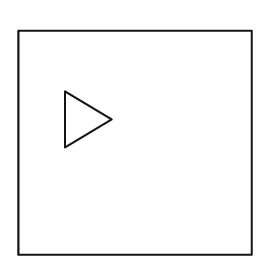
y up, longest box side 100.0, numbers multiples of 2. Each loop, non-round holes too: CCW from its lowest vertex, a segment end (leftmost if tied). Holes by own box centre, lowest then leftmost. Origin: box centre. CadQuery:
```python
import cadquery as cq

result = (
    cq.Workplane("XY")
    .moveTo(-50.0, -48.0)
    .lineTo(50.0, -48.0)
    .lineTo(50.0, 48.0)
    .lineTo(-50.0, 48.0)
    .close()
    .moveTo(-30.0, -2.0)
    .lineTo(-10.0, 10.0)
    .lineTo(-30.0, 22.0)
    .close()
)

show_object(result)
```